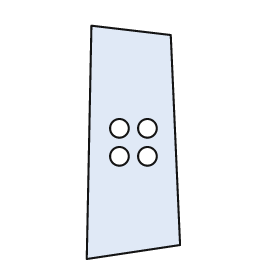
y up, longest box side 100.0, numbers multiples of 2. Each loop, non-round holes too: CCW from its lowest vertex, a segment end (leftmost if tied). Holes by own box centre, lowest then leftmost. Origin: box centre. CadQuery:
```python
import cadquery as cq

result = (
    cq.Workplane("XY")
    .moveTo(-20.0, -50.0)
    .lineTo(20.0, -44.0)
    .lineTo(16.0, 46.0)
    .lineTo(-18.0, 50.0)
    .close()
    .moveTo(-6.0, -6.0)
    .circle(4.0)
    .moveTo(6.0, -6.0)
    .circle(4.0)
    .moveTo(-6.0, 6.0)
    .circle(4.0)
    .moveTo(6.0, 6.0)
    .circle(4.0)
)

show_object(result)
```